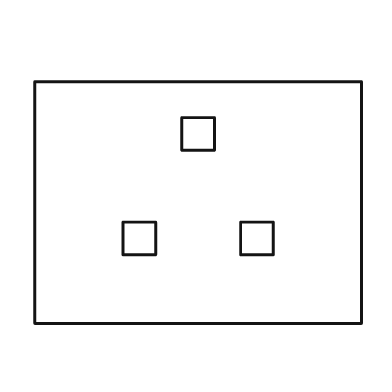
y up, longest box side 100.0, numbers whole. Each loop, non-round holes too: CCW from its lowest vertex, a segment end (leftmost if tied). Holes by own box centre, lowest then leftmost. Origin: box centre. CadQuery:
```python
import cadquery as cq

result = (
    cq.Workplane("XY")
    .moveTo(-50.0, -37.0)
    .lineTo(50.0, -37.0)
    .lineTo(50.0, 37.0)
    .lineTo(-50.0, 37.0)
    .close()
    .moveTo(-23.0, -16.0)
    .lineTo(-13.0, -16.0)
    .lineTo(-13.0, -6.0)
    .lineTo(-23.0, -6.0)
    .close()
    .moveTo(13.0, -16.0)
    .lineTo(23.0, -16.0)
    .lineTo(23.0, -6.0)
    .lineTo(13.0, -6.0)
    .close()
    .moveTo(-5.0, 16.0)
    .lineTo(5.0, 16.0)
    .lineTo(5.0, 26.0)
    .lineTo(-5.0, 26.0)
    .close()
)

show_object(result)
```